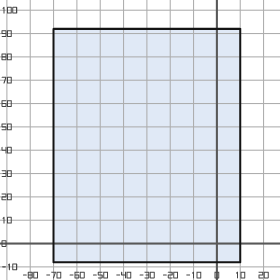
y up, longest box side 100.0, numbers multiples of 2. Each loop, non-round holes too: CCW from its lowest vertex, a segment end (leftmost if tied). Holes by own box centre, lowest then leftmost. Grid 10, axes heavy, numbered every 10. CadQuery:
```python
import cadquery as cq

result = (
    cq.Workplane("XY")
    .moveTo(-70.0, -8.0)
    .lineTo(10.0, -8.0)
    .lineTo(10.0, 92.0)
    .lineTo(-70.0, 92.0)
    .close()
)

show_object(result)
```